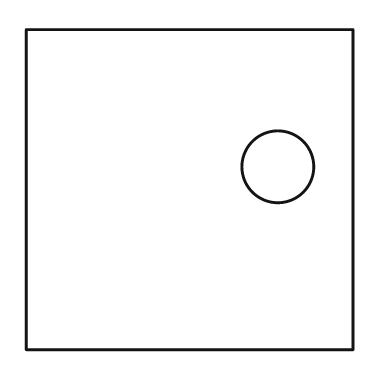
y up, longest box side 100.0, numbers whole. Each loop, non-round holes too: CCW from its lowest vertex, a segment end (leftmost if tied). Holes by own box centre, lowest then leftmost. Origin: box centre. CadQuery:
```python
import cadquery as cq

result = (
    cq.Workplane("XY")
    .moveTo(-50.0, -49.0)
    .lineTo(50.0, -49.0)
    .lineTo(50.0, 49.0)
    .lineTo(-50.0, 49.0)
    .close()
    .moveTo(27.0, 7.0)
    .circle(11.0)
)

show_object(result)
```